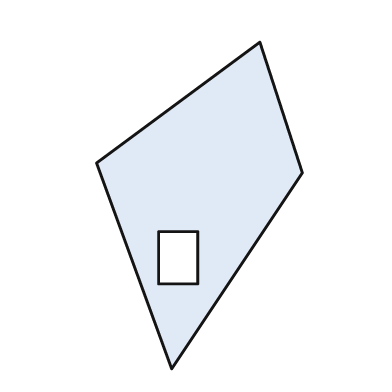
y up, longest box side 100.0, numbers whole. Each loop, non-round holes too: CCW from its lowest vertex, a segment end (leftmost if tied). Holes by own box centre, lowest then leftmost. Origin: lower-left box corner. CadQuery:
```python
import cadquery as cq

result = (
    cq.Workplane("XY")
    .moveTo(23.0, 0.0)
    .lineTo(63.0, 60.0)
    .lineTo(50.0, 100.0)
    .lineTo(0.0, 63.0)
    .close()
    .moveTo(19.0, 26.0)
    .lineTo(31.0, 26.0)
    .lineTo(31.0, 42.0)
    .lineTo(19.0, 42.0)
    .close()
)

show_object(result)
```